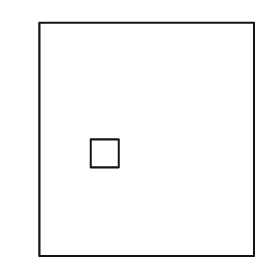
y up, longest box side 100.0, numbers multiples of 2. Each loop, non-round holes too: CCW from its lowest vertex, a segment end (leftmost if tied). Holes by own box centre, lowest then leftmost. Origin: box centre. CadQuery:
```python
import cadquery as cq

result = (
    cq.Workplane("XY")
    .moveTo(-46.0, -50.0)
    .lineTo(46.0, -50.0)
    .lineTo(46.0, 50.0)
    .lineTo(-46.0, 50.0)
    .close()
    .moveTo(-24.0, -12.0)
    .lineTo(-12.0, -12.0)
    .lineTo(-12.0, 0.0)
    .lineTo(-24.0, 0.0)
    .close()
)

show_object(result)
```